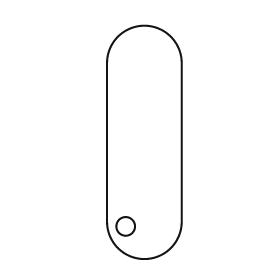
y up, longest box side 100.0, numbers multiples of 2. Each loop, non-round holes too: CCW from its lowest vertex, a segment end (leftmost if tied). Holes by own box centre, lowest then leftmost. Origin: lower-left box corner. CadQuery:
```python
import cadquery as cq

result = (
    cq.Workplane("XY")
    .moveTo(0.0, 16.0)
    .threePointArc((16.0, 0.0), (32.0, 16.0))
    .lineTo(32.0, 84.0)
    .threePointArc((16.0, 100.0), (0.0, 84.0))
    .close()
    .moveTo(8.0, 14.0)
    .circle(4.0)
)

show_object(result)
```